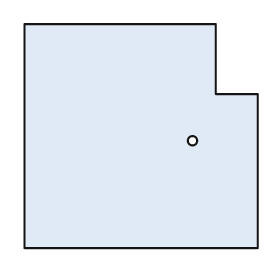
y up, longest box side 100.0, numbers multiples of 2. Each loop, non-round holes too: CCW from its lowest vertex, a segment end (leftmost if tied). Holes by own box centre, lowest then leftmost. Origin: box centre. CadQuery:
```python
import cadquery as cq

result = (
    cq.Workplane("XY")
    .moveTo(-50.0, -48.0)
    .lineTo(50.0, -48.0)
    .lineTo(50.0, 18.0)
    .lineTo(32.0, 18.0)
    .lineTo(32.0, 48.0)
    .lineTo(-50.0, 48.0)
    .close()
    .moveTo(22.0, -2.0)
    .circle(2.0)
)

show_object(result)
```